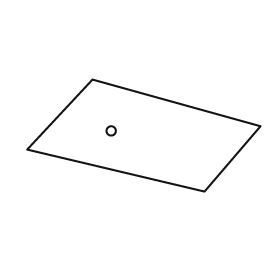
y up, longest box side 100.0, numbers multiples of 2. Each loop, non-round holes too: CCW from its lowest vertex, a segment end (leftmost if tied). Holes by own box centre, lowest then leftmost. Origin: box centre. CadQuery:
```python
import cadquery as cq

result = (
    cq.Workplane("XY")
    .moveTo(26.0, -24.0)
    .lineTo(50.0, 4.0)
    .lineTo(-22.0, 24.0)
    .lineTo(-50.0, -6.0)
    .close()
    .moveTo(-14.0, 2.0)
    .circle(2.0)
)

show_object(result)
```